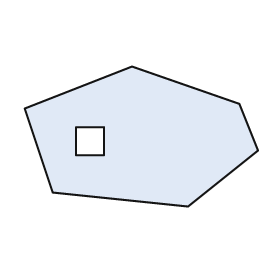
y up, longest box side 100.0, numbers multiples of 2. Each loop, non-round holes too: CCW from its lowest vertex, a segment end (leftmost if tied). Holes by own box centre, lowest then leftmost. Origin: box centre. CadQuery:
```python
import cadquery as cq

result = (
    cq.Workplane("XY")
    .moveTo(20.0, -30.0)
    .lineTo(50.0, -6.0)
    .lineTo(42.0, 14.0)
    .lineTo(-4.0, 30.0)
    .lineTo(-50.0, 12.0)
    .lineTo(-38.0, -24.0)
    .close()
    .moveTo(-28.0, -8.0)
    .lineTo(-16.0, -8.0)
    .lineTo(-16.0, 4.0)
    .lineTo(-28.0, 4.0)
    .close()
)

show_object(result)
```